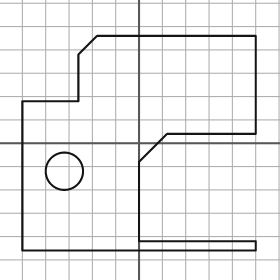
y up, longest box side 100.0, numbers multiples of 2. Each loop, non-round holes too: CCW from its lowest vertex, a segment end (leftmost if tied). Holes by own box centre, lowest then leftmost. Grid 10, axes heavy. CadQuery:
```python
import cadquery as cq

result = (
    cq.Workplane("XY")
    .moveTo(-50.0, -46.0)
    .lineTo(50.0, -46.0)
    .lineTo(50.0, -42.0)
    .lineTo(0.0, -42.0)
    .lineTo(0.0, -8.0)
    .lineTo(12.0, 4.0)
    .lineTo(50.0, 4.0)
    .lineTo(50.0, 46.0)
    .lineTo(-18.0, 46.0)
    .lineTo(-26.0, 38.0)
    .lineTo(-26.0, 18.0)
    .lineTo(-50.0, 18.0)
    .close()
    .moveTo(-32.0, -12.0)
    .circle(8.0)
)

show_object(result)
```